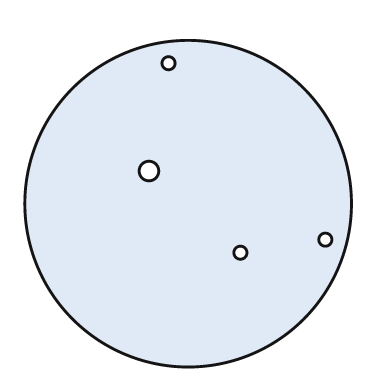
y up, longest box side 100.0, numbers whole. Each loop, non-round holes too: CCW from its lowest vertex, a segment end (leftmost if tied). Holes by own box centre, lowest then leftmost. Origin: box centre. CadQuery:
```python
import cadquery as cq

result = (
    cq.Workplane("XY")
    .moveTo(0.0, 0.0)
    .circle(50.0)
    .moveTo(16.0, -15.0)
    .circle(2.0)
    .moveTo(42.0, -11.0)
    .circle(2.0)
    .moveTo(-12.0, 10.0)
    .circle(3.0)
    .moveTo(-6.0, 43.0)
    .circle(2.0)
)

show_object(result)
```